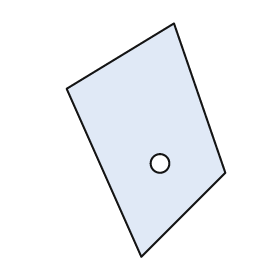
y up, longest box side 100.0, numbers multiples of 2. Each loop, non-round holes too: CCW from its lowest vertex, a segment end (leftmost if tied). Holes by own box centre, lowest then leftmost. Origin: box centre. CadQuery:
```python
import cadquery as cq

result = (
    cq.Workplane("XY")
    .moveTo(-2.0, -50.0)
    .lineTo(34.0, -14.0)
    .lineTo(12.0, 50.0)
    .lineTo(-34.0, 22.0)
    .close()
    .moveTo(6.0, -10.0)
    .circle(4.0)
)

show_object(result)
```